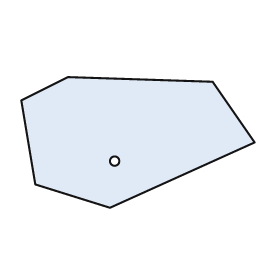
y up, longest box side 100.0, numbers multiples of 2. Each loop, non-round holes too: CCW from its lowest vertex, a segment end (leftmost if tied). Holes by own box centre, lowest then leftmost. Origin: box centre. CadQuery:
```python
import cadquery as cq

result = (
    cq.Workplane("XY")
    .moveTo(-12.0, -28.0)
    .lineTo(50.0, 0.0)
    .lineTo(32.0, 26.0)
    .lineTo(-30.0, 28.0)
    .lineTo(-50.0, 18.0)
    .lineTo(-44.0, -18.0)
    .close()
    .moveTo(-10.0, -8.0)
    .circle(2.0)
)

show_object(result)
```